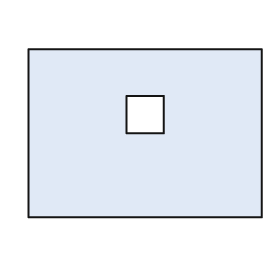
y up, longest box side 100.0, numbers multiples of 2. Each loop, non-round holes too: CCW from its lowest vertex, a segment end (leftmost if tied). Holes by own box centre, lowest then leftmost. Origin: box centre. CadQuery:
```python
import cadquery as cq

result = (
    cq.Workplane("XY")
    .moveTo(-50.0, -36.0)
    .lineTo(50.0, -36.0)
    .lineTo(50.0, 36.0)
    .lineTo(-50.0, 36.0)
    .close()
    .moveTo(-8.0, 0.0)
    .lineTo(8.0, 0.0)
    .lineTo(8.0, 16.0)
    .lineTo(-8.0, 16.0)
    .close()
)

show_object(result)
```